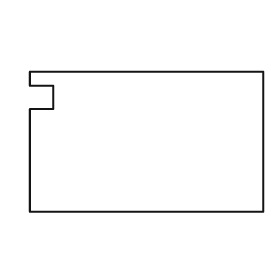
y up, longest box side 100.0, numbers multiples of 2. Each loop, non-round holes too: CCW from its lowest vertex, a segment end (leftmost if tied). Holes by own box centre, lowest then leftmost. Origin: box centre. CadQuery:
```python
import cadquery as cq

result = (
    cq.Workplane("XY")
    .moveTo(-50.0, -30.0)
    .lineTo(50.0, -30.0)
    .lineTo(50.0, 30.0)
    .lineTo(-50.0, 30.0)
    .lineTo(-50.0, 24.0)
    .lineTo(-40.0, 24.0)
    .lineTo(-40.0, 14.0)
    .lineTo(-50.0, 14.0)
    .close()
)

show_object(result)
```